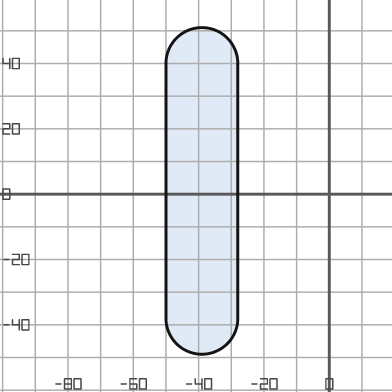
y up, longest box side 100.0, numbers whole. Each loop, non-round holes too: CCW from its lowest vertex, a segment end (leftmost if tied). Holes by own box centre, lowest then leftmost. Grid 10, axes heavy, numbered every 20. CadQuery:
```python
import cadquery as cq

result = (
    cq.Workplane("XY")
    .moveTo(-50.0, -38.0)
    .threePointArc((-39.0, -49.0), (-28.0, -38.0))
    .lineTo(-28.0, 40.0)
    .threePointArc((-39.0, 51.0), (-50.0, 40.0))
    .close()
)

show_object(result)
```